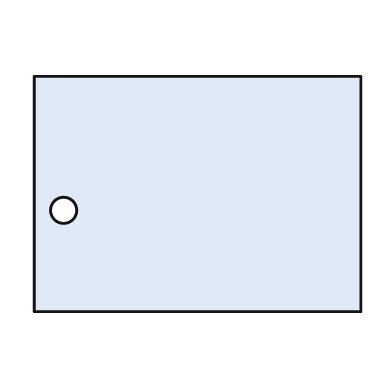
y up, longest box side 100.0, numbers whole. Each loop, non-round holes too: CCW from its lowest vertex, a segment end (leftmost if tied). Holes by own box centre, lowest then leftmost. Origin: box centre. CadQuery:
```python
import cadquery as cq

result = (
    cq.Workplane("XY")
    .moveTo(-50.0, -36.0)
    .lineTo(50.0, -36.0)
    .lineTo(50.0, 36.0)
    .lineTo(-50.0, 36.0)
    .close()
    .moveTo(-41.0, -5.0)
    .circle(4.0)
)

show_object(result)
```